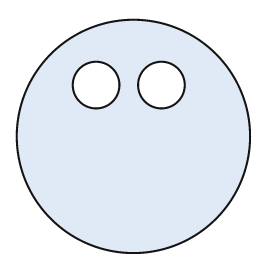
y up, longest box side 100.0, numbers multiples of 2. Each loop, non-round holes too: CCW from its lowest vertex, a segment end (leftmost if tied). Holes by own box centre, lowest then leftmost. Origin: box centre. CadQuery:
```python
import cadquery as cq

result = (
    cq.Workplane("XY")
    .moveTo(0.0, 0.0)
    .circle(50.0)
    .moveTo(-16.0, 22.0)
    .circle(10.0)
    .moveTo(12.0, 22.0)
    .circle(10.0)
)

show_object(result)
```